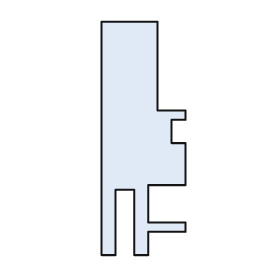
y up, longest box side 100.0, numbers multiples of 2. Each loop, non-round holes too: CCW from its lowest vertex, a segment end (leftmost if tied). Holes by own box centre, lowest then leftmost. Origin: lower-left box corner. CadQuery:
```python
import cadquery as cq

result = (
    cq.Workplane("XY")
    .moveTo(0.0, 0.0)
    .lineTo(6.0, 0.0)
    .lineTo(6.0, 28.0)
    .lineTo(14.0, 28.0)
    .lineTo(14.0, 0.0)
    .lineTo(20.0, 0.0)
    .lineTo(20.0, 10.0)
    .lineTo(36.0, 10.0)
    .lineTo(36.0, 14.0)
    .lineTo(20.0, 14.0)
    .lineTo(20.0, 30.0)
    .lineTo(36.0, 30.0)
    .lineTo(36.0, 48.0)
    .lineTo(30.0, 48.0)
    .lineTo(30.0, 58.0)
    .lineTo(36.0, 58.0)
    .lineTo(36.0, 62.0)
    .lineTo(24.0, 62.0)
    .lineTo(24.0, 100.0)
    .lineTo(0.0, 100.0)
    .close()
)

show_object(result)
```